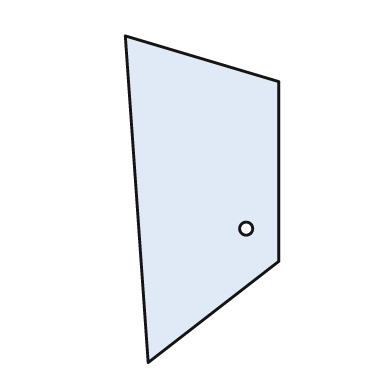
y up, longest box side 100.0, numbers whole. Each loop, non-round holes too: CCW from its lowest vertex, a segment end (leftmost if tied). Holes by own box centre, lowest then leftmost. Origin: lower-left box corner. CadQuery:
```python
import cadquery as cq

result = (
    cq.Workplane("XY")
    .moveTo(7.0, 0.0)
    .lineTo(47.0, 31.0)
    .lineTo(47.0, 86.0)
    .lineTo(0.0, 100.0)
    .close()
    .moveTo(37.0, 41.0)
    .circle(2.0)
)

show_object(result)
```